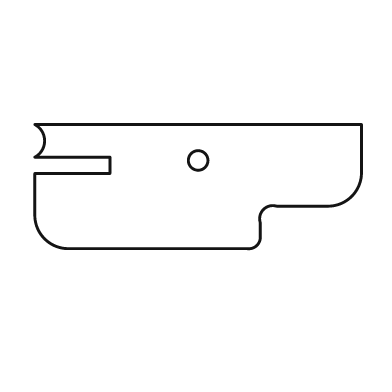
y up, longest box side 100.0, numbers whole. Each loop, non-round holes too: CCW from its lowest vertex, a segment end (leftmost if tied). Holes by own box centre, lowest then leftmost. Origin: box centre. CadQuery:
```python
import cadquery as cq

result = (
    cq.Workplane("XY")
    .moveTo(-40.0, -19.0)
    .lineTo(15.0, -19.0)
    .threePointArc((18.0, -18.0), (19.0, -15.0))
    .lineTo(19.0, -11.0)
    .threePointArc((20.0, -7.0), (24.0, -6.0))
    .lineTo(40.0, -6.0)
    .threePointArc((47.0, -3.0), (50.0, 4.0))
    .lineTo(50.0, 19.0)
    .lineTo(-50.0, 19.0)
    .threePointArc((-47.0, 14.0), (-50.0, 9.0))
    .lineTo(-27.0, 9.0)
    .lineTo(-27.0, 4.0)
    .lineTo(-50.0, 4.0)
    .lineTo(-50.0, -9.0)
    .threePointArc((-47.0, -16.0), (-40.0, -19.0))
    .close()
    .moveTo(0.0, 8.0)
    .circle(3.0)
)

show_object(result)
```